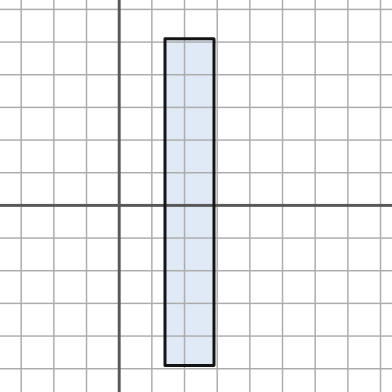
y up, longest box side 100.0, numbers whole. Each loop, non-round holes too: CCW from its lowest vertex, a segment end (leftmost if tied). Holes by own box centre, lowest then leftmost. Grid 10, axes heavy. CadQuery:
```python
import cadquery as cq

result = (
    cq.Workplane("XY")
    .moveTo(14.0, -49.0)
    .lineTo(29.0, -49.0)
    .lineTo(29.0, 51.0)
    .lineTo(14.0, 51.0)
    .close()
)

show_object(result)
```